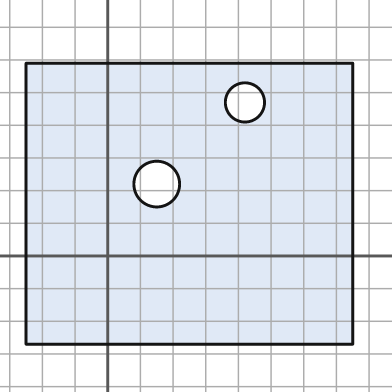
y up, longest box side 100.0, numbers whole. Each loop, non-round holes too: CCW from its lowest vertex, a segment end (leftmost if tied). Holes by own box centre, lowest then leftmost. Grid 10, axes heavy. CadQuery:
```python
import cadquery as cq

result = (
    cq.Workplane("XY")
    .moveTo(-25.0, -27.0)
    .lineTo(75.0, -27.0)
    .lineTo(75.0, 59.0)
    .lineTo(-25.0, 59.0)
    .close()
    .moveTo(15.0, 22.0)
    .circle(7.0)
    .moveTo(42.0, 47.0)
    .circle(6.0)
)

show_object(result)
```